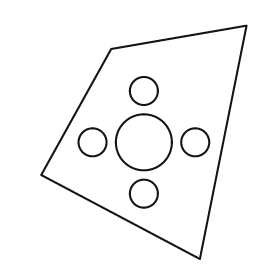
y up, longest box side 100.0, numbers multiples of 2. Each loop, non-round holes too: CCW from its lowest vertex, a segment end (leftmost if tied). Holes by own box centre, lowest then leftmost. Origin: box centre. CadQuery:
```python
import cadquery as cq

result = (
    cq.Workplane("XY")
    .moveTo(24.0, -50.0)
    .lineTo(44.0, 50.0)
    .lineTo(-14.0, 40.0)
    .lineTo(-44.0, -14.0)
    .close()
    .moveTo(0.0, -22.0)
    .circle(6.0)
    .moveTo(-22.0, 0.0)
    .circle(6.0)
    .moveTo(0.0, 0.0)
    .circle(12.0)
    .moveTo(22.0, 0.0)
    .circle(6.0)
    .moveTo(0.0, 22.0)
    .circle(6.0)
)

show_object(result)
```